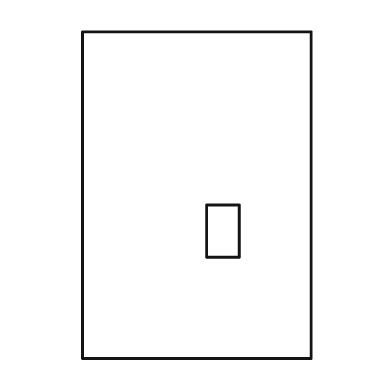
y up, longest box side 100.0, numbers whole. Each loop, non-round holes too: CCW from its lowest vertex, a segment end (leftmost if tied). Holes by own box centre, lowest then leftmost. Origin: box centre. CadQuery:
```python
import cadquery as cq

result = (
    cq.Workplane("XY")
    .moveTo(-35.0, -50.0)
    .lineTo(35.0, -50.0)
    .lineTo(35.0, 50.0)
    .lineTo(-35.0, 50.0)
    .close()
    .moveTo(3.0, -19.0)
    .lineTo(13.0, -19.0)
    .lineTo(13.0, -3.0)
    .lineTo(3.0, -3.0)
    .close()
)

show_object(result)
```